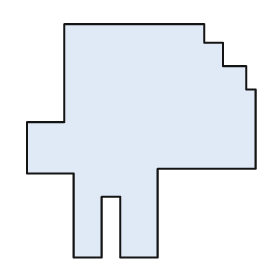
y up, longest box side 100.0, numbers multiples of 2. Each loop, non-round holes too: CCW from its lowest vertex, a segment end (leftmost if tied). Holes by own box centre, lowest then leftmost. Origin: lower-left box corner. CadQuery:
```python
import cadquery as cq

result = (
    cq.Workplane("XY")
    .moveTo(20.0, 0.0)
    .lineTo(32.0, 0.0)
    .lineTo(32.0, 26.0)
    .lineTo(40.0, 26.0)
    .lineTo(40.0, 0.0)
    .lineTo(56.0, 0.0)
    .lineTo(56.0, 38.0)
    .lineTo(98.0, 38.0)
    .lineTo(98.0, 72.0)
    .lineTo(94.0, 72.0)
    .lineTo(94.0, 82.0)
    .lineTo(84.0, 82.0)
    .lineTo(84.0, 92.0)
    .lineTo(76.0, 92.0)
    .lineTo(76.0, 100.0)
    .lineTo(16.0, 100.0)
    .lineTo(16.0, 58.0)
    .lineTo(0.0, 58.0)
    .lineTo(0.0, 36.0)
    .lineTo(20.0, 36.0)
    .close()
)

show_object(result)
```